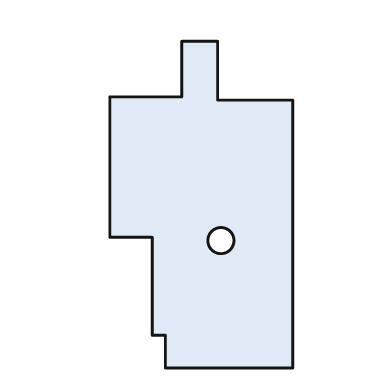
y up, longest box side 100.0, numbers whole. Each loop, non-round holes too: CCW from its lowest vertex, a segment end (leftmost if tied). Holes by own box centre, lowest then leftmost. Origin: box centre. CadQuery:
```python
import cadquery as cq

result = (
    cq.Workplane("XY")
    .moveTo(-11.0, -50.0)
    .lineTo(28.0, -50.0)
    .lineTo(28.0, 32.0)
    .lineTo(5.0, 32.0)
    .lineTo(5.0, 50.0)
    .lineTo(-6.0, 50.0)
    .lineTo(-6.0, 33.0)
    .lineTo(-28.0, 33.0)
    .lineTo(-28.0, -10.0)
    .lineTo(-15.0, -10.0)
    .lineTo(-15.0, -40.0)
    .lineTo(-11.0, -40.0)
    .close()
    .moveTo(6.0, -11.0)
    .circle(4.0)
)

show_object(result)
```